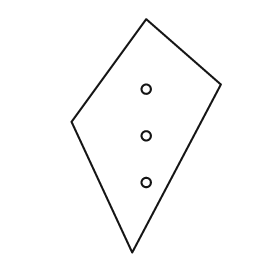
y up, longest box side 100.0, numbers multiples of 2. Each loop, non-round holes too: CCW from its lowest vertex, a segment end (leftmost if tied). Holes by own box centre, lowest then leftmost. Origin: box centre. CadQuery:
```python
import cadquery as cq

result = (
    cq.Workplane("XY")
    .moveTo(-6.0, -50.0)
    .lineTo(32.0, 22.0)
    .lineTo(0.0, 50.0)
    .lineTo(-32.0, 6.0)
    .close()
    .moveTo(0.0, -20.0)
    .circle(2.0)
    .moveTo(0.0, 0.0)
    .circle(2.0)
    .moveTo(0.0, 20.0)
    .circle(2.0)
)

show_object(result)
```